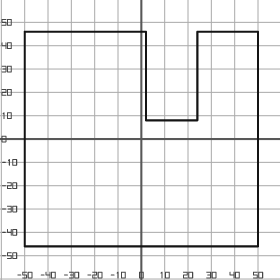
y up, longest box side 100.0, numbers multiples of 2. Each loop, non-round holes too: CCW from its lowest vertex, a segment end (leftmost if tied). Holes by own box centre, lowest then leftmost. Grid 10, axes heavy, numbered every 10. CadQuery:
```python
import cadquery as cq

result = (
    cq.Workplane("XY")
    .moveTo(-50.0, -46.0)
    .lineTo(50.0, -46.0)
    .lineTo(50.0, 46.0)
    .lineTo(24.0, 46.0)
    .lineTo(24.0, 8.0)
    .lineTo(2.0, 8.0)
    .lineTo(2.0, 46.0)
    .lineTo(-50.0, 46.0)
    .close()
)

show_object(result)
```